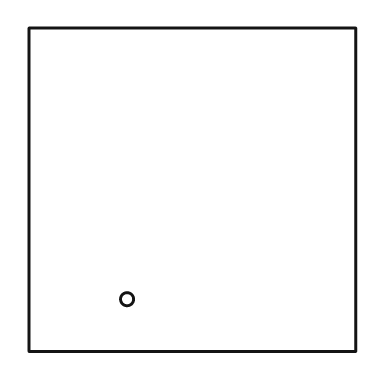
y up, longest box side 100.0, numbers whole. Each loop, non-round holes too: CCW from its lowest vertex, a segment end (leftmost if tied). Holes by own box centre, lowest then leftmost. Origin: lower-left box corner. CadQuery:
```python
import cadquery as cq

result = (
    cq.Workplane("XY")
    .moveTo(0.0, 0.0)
    .lineTo(100.0, 0.0)
    .lineTo(100.0, 99.0)
    .lineTo(0.0, 99.0)
    .close()
    .moveTo(30.0, 16.0)
    .circle(2.0)
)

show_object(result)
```